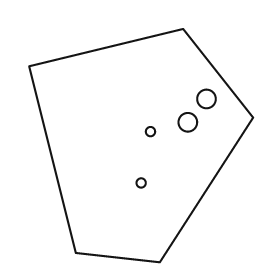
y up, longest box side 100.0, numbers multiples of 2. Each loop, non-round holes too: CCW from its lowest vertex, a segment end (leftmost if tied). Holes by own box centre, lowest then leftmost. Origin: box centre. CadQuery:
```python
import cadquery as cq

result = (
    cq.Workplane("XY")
    .moveTo(8.0, -50.0)
    .lineTo(48.0, 12.0)
    .lineTo(18.0, 50.0)
    .lineTo(-48.0, 34.0)
    .lineTo(-28.0, -46.0)
    .close()
    .moveTo(0.0, -16.0)
    .circle(2.0)
    .moveTo(4.0, 6.0)
    .circle(2.0)
    .moveTo(20.0, 10.0)
    .circle(4.0)
    .moveTo(28.0, 20.0)
    .circle(4.0)
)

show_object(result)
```